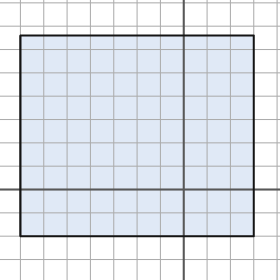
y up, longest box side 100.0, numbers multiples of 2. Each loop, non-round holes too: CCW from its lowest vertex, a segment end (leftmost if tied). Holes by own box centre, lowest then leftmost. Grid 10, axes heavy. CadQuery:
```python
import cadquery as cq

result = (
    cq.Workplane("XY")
    .moveTo(-70.0, -20.0)
    .lineTo(30.0, -20.0)
    .lineTo(30.0, 66.0)
    .lineTo(-70.0, 66.0)
    .close()
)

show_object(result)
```